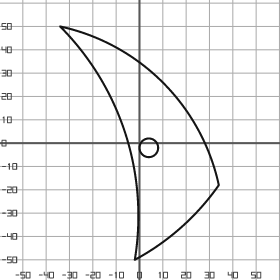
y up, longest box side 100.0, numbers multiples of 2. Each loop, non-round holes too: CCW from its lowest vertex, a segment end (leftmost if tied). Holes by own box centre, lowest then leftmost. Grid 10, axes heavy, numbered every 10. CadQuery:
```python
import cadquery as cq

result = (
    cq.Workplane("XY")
    .moveTo(-2.0, -50.0)
    .threePointArc((18.0, -36.0), (34.0, -18.0))
    .threePointArc((10.0, 26.0), (-34.0, 50.0))
    .threePointArc((-6.0, 4.0), (-2.0, -50.0))
    .close()
    .moveTo(4.0, -2.0)
    .circle(4.0)
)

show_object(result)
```